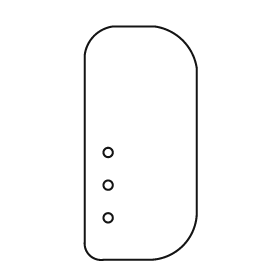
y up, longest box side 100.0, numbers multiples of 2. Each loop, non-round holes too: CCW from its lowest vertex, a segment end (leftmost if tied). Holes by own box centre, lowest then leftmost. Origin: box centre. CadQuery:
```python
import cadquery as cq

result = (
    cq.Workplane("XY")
    .moveTo(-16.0, -50.0)
    .lineTo(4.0, -50.0)
    .threePointArc((18.0, -44.0), (24.0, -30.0))
    .lineTo(24.0, 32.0)
    .threePointArc((18.0, 44.0), (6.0, 50.0))
    .lineTo(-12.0, 50.0)
    .threePointArc((-20.0, 46.0), (-24.0, 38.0))
    .lineTo(-24.0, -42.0)
    .threePointArc((-22.0, -48.0), (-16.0, -50.0))
    .close()
    .moveTo(-14.0, -32.0)
    .circle(2.0)
    .moveTo(-14.0, -18.0)
    .circle(2.0)
    .moveTo(-14.0, -4.0)
    .circle(2.0)
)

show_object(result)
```